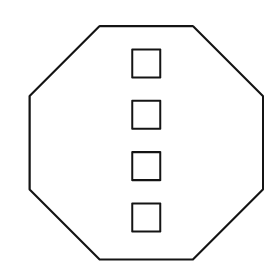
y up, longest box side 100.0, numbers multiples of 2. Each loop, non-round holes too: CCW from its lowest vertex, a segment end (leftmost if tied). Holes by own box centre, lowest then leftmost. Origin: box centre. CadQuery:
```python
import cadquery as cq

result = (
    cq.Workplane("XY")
    .moveTo(-20.0, -50.0)
    .lineTo(20.0, -50.0)
    .lineTo(50.0, -20.0)
    .lineTo(50.0, 20.0)
    .lineTo(20.0, 50.0)
    .lineTo(-20.0, 50.0)
    .lineTo(-50.0, 20.0)
    .lineTo(-50.0, -20.0)
    .close()
    .moveTo(-6.0, -38.0)
    .lineTo(6.0, -38.0)
    .lineTo(6.0, -26.0)
    .lineTo(-6.0, -26.0)
    .close()
    .moveTo(-6.0, -16.0)
    .lineTo(6.0, -16.0)
    .lineTo(6.0, -4.0)
    .lineTo(-6.0, -4.0)
    .close()
    .moveTo(-6.0, 6.0)
    .lineTo(6.0, 6.0)
    .lineTo(6.0, 18.0)
    .lineTo(-6.0, 18.0)
    .close()
    .moveTo(-6.0, 28.0)
    .lineTo(6.0, 28.0)
    .lineTo(6.0, 40.0)
    .lineTo(-6.0, 40.0)
    .close()
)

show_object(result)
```